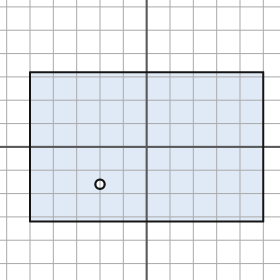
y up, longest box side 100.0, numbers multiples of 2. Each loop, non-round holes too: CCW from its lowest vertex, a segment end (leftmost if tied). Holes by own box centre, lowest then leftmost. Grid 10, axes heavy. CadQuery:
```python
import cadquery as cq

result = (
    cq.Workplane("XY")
    .moveTo(-50.0, -32.0)
    .lineTo(50.0, -32.0)
    .lineTo(50.0, 32.0)
    .lineTo(-50.0, 32.0)
    .close()
    .moveTo(-20.0, -16.0)
    .circle(2.0)
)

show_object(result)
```